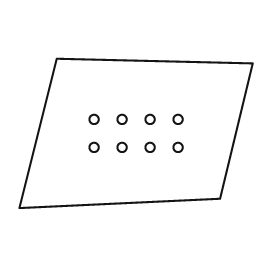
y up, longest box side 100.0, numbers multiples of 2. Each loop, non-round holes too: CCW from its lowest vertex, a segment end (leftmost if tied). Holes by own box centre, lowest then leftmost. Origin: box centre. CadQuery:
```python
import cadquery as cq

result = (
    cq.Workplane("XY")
    .moveTo(-50.0, -32.0)
    .lineTo(36.0, -28.0)
    .lineTo(50.0, 30.0)
    .lineTo(-34.0, 32.0)
    .close()
    .moveTo(-18.0, -6.0)
    .circle(2.0)
    .moveTo(-6.0, -6.0)
    .circle(2.0)
    .moveTo(6.0, -6.0)
    .circle(2.0)
    .moveTo(18.0, -6.0)
    .circle(2.0)
    .moveTo(-18.0, 6.0)
    .circle(2.0)
    .moveTo(-6.0, 6.0)
    .circle(2.0)
    .moveTo(6.0, 6.0)
    .circle(2.0)
    .moveTo(18.0, 6.0)
    .circle(2.0)
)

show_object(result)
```